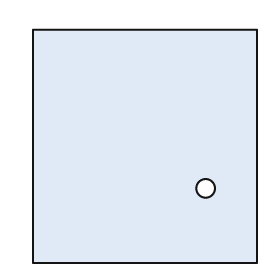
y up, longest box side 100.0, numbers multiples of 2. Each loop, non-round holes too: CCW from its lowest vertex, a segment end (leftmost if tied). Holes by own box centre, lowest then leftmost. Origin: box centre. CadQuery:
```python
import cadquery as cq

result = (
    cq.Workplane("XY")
    .moveTo(-48.0, -50.0)
    .lineTo(48.0, -50.0)
    .lineTo(48.0, 50.0)
    .lineTo(-48.0, 50.0)
    .close()
    .moveTo(26.0, -18.0)
    .circle(4.0)
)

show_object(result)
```